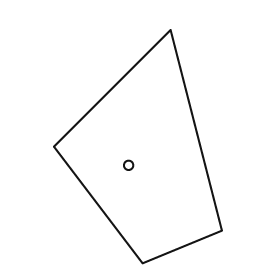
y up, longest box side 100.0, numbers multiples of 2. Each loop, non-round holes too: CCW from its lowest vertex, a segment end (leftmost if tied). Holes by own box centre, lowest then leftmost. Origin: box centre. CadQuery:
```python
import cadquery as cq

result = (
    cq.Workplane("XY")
    .moveTo(2.0, -50.0)
    .lineTo(36.0, -36.0)
    .lineTo(14.0, 50.0)
    .lineTo(-36.0, 0.0)
    .close()
    .moveTo(-4.0, -8.0)
    .circle(2.0)
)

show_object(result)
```